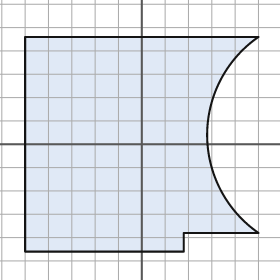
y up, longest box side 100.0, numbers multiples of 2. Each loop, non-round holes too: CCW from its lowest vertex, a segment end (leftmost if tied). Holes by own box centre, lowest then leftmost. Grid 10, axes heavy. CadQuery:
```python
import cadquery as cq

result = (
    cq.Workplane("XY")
    .moveTo(-50.0, -46.0)
    .lineTo(18.0, -46.0)
    .lineTo(18.0, -38.0)
    .lineTo(50.0, -38.0)
    .threePointArc((28.0, 4.0), (50.0, 46.0))
    .lineTo(-50.0, 46.0)
    .close()
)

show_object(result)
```